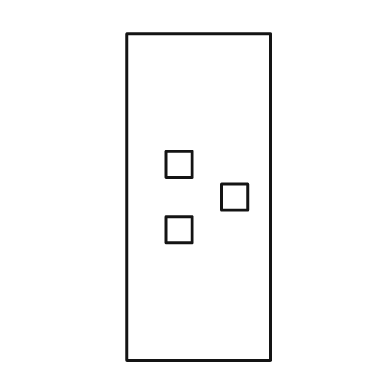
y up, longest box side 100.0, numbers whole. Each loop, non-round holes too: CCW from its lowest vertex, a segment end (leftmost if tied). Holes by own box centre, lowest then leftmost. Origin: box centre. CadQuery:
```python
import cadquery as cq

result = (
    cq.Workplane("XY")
    .moveTo(-22.0, -50.0)
    .lineTo(22.0, -50.0)
    .lineTo(22.0, 50.0)
    .lineTo(-22.0, 50.0)
    .close()
    .moveTo(-10.0, -14.0)
    .lineTo(-2.0, -14.0)
    .lineTo(-2.0, -6.0)
    .lineTo(-10.0, -6.0)
    .close()
    .moveTo(7.0, -4.0)
    .lineTo(15.0, -4.0)
    .lineTo(15.0, 4.0)
    .lineTo(7.0, 4.0)
    .close()
    .moveTo(-10.0, 6.0)
    .lineTo(-2.0, 6.0)
    .lineTo(-2.0, 14.0)
    .lineTo(-10.0, 14.0)
    .close()
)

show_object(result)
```